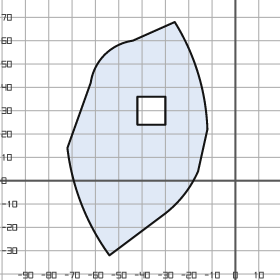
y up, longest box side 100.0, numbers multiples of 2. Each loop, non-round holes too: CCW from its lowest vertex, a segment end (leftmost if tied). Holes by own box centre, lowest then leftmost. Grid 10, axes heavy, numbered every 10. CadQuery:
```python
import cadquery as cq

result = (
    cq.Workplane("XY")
    .moveTo(-54.0, -32.0)
    .lineTo(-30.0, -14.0)
    .threePointArc((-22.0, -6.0), (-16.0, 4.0))
    .lineTo(-12.0, 22.0)
    .threePointArc((-16.0, 46.0), (-26.0, 68.0))
    .lineTo(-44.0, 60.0)
    .threePointArc((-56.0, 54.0), (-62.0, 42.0))
    .lineTo(-72.0, 14.0)
    .threePointArc((-66.0, -10.0), (-54.0, -32.0))
    .close()
    .moveTo(-42.0, 24.0)
    .lineTo(-30.0, 24.0)
    .lineTo(-30.0, 36.0)
    .lineTo(-42.0, 36.0)
    .close()
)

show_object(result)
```